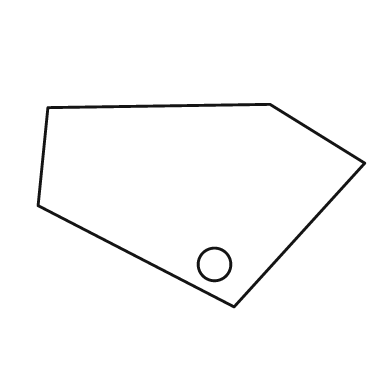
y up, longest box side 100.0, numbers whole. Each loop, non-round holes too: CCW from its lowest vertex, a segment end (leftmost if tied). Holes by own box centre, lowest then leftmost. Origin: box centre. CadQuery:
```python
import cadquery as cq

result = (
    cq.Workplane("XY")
    .moveTo(10.0, -31.0)
    .lineTo(50.0, 13.0)
    .lineTo(21.0, 31.0)
    .lineTo(-47.0, 30.0)
    .lineTo(-50.0, 0.0)
    .close()
    .moveTo(4.0, -18.0)
    .circle(5.0)
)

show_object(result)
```